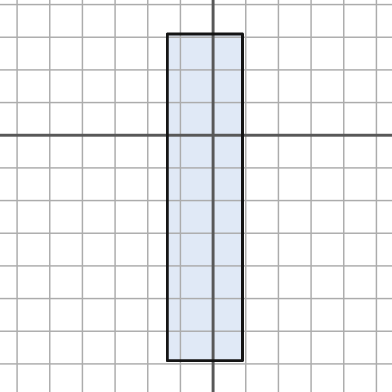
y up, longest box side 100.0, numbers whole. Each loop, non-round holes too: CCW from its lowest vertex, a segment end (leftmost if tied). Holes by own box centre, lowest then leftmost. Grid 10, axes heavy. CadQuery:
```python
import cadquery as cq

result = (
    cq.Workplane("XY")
    .moveTo(-14.0, -69.0)
    .lineTo(9.0, -69.0)
    .lineTo(9.0, 31.0)
    .lineTo(-14.0, 31.0)
    .close()
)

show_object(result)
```